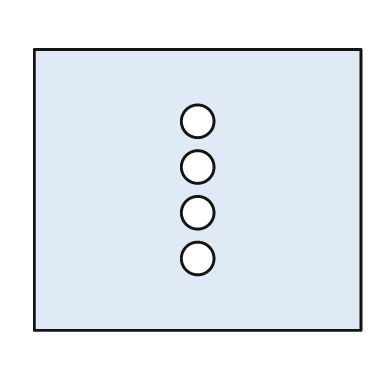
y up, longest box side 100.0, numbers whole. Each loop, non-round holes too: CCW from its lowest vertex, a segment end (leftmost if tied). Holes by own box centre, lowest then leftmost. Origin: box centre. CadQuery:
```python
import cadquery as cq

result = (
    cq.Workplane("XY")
    .moveTo(-50.0, -43.0)
    .lineTo(50.0, -43.0)
    .lineTo(50.0, 43.0)
    .lineTo(-50.0, 43.0)
    .close()
    .moveTo(0.0, -21.0)
    .circle(5.0)
    .moveTo(0.0, -7.0)
    .circle(5.0)
    .moveTo(0.0, 7.0)
    .circle(5.0)
    .moveTo(0.0, 21.0)
    .circle(5.0)
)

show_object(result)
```